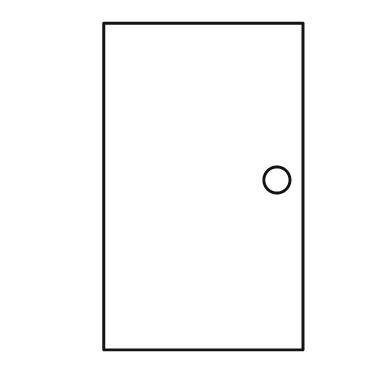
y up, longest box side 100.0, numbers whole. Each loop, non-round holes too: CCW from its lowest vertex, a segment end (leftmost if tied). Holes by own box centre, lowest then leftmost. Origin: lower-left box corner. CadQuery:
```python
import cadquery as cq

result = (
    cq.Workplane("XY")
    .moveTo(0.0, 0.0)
    .lineTo(61.0, 0.0)
    .lineTo(61.0, 100.0)
    .lineTo(0.0, 100.0)
    .close()
    .moveTo(53.0, 52.0)
    .circle(4.0)
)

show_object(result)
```